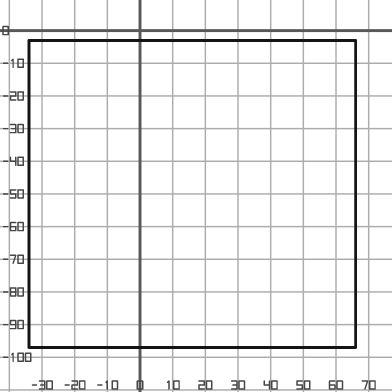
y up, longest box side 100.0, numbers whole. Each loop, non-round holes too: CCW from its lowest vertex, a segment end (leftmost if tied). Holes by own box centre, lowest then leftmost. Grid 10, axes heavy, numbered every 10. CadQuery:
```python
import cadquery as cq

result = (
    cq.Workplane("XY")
    .moveTo(-34.0, -97.0)
    .lineTo(66.0, -97.0)
    .lineTo(66.0, -3.0)
    .lineTo(-34.0, -3.0)
    .close()
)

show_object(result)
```